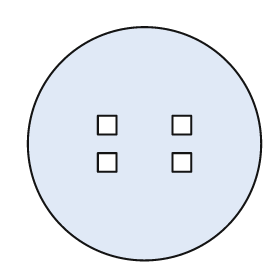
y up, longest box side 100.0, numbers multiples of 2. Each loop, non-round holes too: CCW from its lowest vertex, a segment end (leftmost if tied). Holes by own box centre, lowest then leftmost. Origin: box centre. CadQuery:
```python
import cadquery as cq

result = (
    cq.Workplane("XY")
    .moveTo(0.0, 0.0)
    .circle(50.0)
    .moveTo(-20.0, -12.0)
    .lineTo(-12.0, -12.0)
    .lineTo(-12.0, -4.0)
    .lineTo(-20.0, -4.0)
    .close()
    .moveTo(12.0, -12.0)
    .lineTo(20.0, -12.0)
    .lineTo(20.0, -4.0)
    .lineTo(12.0, -4.0)
    .close()
    .moveTo(-20.0, 4.0)
    .lineTo(-12.0, 4.0)
    .lineTo(-12.0, 12.0)
    .lineTo(-20.0, 12.0)
    .close()
    .moveTo(12.0, 4.0)
    .lineTo(20.0, 4.0)
    .lineTo(20.0, 12.0)
    .lineTo(12.0, 12.0)
    .close()
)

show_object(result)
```